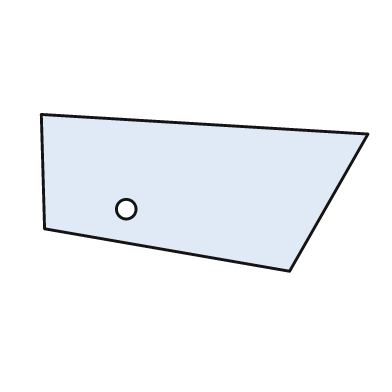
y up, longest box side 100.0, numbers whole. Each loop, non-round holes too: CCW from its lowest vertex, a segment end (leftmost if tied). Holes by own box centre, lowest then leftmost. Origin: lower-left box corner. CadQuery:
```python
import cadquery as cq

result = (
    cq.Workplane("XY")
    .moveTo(76.0, 0.0)
    .lineTo(100.0, 42.0)
    .lineTo(0.0, 48.0)
    .lineTo(1.0, 13.0)
    .close()
    .moveTo(26.0, 19.0)
    .circle(3.0)
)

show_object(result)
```